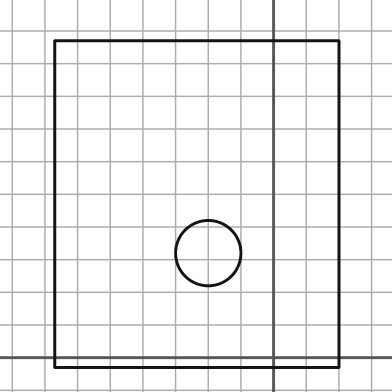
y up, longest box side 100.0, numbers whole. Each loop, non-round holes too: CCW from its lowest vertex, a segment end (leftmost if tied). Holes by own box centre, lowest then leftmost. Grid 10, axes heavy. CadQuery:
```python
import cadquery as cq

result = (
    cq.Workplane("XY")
    .moveTo(-67.0, -3.0)
    .lineTo(20.0, -3.0)
    .lineTo(20.0, 97.0)
    .lineTo(-67.0, 97.0)
    .close()
    .moveTo(-20.0, 32.0)
    .circle(10.0)
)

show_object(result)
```